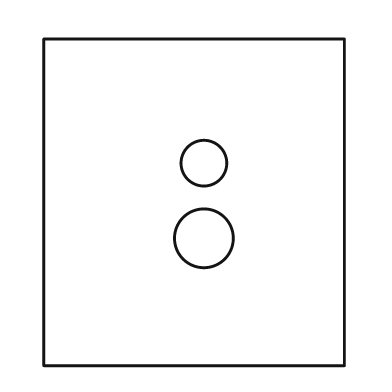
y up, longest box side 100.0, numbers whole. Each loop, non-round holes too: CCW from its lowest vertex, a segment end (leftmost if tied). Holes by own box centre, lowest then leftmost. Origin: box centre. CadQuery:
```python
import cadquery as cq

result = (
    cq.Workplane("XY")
    .moveTo(-46.0, -50.0)
    .lineTo(46.0, -50.0)
    .lineTo(46.0, 50.0)
    .lineTo(-46.0, 50.0)
    .close()
    .moveTo(3.0, -11.0)
    .circle(9.0)
    .moveTo(3.0, 12.0)
    .circle(7.0)
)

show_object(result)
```